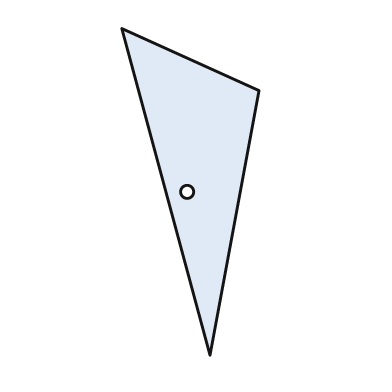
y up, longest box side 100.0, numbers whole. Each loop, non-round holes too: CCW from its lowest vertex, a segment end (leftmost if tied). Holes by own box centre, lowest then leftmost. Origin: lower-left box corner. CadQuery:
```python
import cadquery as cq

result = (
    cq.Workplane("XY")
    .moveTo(27.0, 0.0)
    .lineTo(42.0, 81.0)
    .lineTo(0.0, 100.0)
    .close()
    .moveTo(20.0, 50.0)
    .circle(2.0)
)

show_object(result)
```